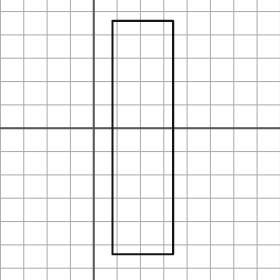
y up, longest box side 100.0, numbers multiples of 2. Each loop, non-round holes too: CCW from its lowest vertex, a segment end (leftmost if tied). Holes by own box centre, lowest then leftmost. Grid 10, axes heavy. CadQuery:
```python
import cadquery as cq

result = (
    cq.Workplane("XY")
    .moveTo(8.0, -54.0)
    .lineTo(34.0, -54.0)
    .lineTo(34.0, 46.0)
    .lineTo(8.0, 46.0)
    .close()
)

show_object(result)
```